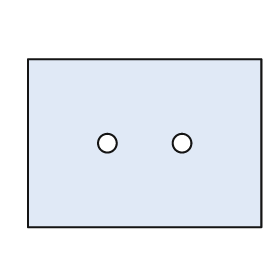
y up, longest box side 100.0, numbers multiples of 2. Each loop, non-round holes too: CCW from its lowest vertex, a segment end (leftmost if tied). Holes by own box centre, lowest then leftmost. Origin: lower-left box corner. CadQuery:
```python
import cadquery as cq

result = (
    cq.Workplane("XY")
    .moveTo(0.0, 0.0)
    .lineTo(100.0, 0.0)
    .lineTo(100.0, 72.0)
    .lineTo(0.0, 72.0)
    .close()
    .moveTo(34.0, 36.0)
    .circle(4.0)
    .moveTo(66.0, 36.0)
    .circle(4.0)
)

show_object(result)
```